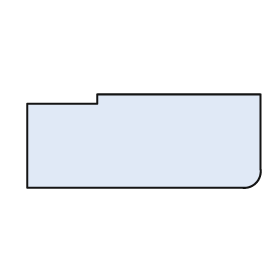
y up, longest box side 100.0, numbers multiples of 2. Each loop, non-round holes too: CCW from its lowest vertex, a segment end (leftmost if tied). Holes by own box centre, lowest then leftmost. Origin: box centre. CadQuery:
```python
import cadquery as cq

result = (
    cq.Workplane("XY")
    .moveTo(-50.0, -20.0)
    .lineTo(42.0, -20.0)
    .threePointArc((48.0, -18.0), (50.0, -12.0))
    .lineTo(50.0, 20.0)
    .lineTo(-20.0, 20.0)
    .lineTo(-20.0, 16.0)
    .lineTo(-50.0, 16.0)
    .close()
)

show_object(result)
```